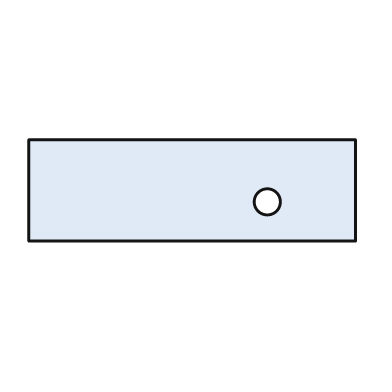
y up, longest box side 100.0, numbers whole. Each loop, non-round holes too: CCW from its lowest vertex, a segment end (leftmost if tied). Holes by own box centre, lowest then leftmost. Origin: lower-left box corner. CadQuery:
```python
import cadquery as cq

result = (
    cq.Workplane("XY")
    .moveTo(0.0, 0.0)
    .lineTo(100.0, 0.0)
    .lineTo(100.0, 31.0)
    .lineTo(0.0, 31.0)
    .close()
    .moveTo(73.0, 12.0)
    .circle(4.0)
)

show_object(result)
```